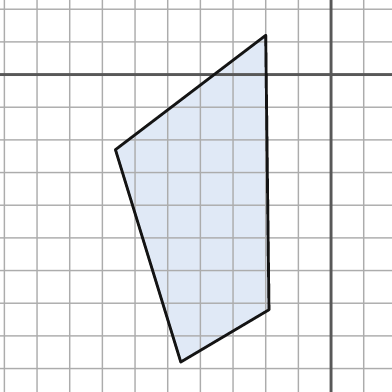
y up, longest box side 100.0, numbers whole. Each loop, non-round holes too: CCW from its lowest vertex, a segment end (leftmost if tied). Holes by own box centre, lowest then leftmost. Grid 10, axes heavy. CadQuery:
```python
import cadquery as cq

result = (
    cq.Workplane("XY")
    .moveTo(-46.0, -88.0)
    .lineTo(-19.0, -72.0)
    .lineTo(-20.0, 12.0)
    .lineTo(-66.0, -23.0)
    .close()
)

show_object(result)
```